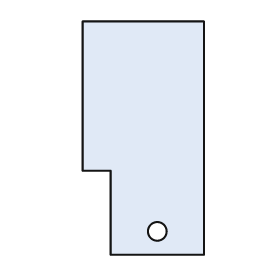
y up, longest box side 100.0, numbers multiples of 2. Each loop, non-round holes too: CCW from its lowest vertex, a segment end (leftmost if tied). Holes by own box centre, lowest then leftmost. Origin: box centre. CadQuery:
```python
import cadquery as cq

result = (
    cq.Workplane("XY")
    .moveTo(-14.0, -50.0)
    .lineTo(26.0, -50.0)
    .lineTo(26.0, 50.0)
    .lineTo(-26.0, 50.0)
    .lineTo(-26.0, -14.0)
    .lineTo(-14.0, -14.0)
    .close()
    .moveTo(6.0, -40.0)
    .circle(4.0)
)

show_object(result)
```